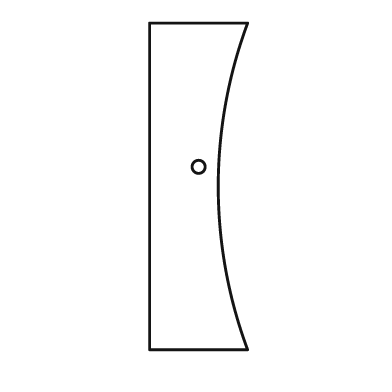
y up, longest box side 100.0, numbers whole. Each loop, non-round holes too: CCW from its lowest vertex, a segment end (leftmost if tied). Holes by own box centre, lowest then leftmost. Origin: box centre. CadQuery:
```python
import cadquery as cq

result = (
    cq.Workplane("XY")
    .moveTo(-15.0, -50.0)
    .lineTo(15.0, -50.0)
    .threePointArc((6.0, 0.0), (15.0, 50.0))
    .lineTo(-15.0, 50.0)
    .close()
    .moveTo(0.0, 6.0)
    .circle(2.0)
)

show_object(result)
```